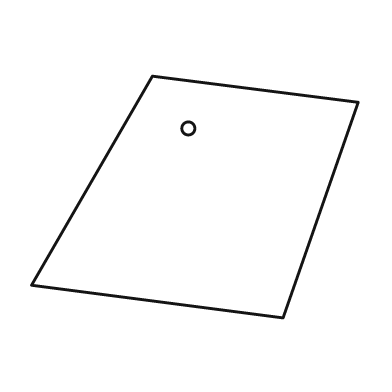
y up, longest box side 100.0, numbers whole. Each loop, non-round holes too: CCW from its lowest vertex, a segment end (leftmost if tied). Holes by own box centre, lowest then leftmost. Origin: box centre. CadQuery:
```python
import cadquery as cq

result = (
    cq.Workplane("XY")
    .moveTo(27.0, -37.0)
    .lineTo(50.0, 29.0)
    .lineTo(-13.0, 37.0)
    .lineTo(-50.0, -27.0)
    .close()
    .moveTo(-2.0, 21.0)
    .circle(2.0)
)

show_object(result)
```